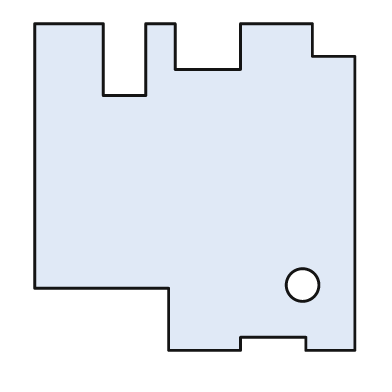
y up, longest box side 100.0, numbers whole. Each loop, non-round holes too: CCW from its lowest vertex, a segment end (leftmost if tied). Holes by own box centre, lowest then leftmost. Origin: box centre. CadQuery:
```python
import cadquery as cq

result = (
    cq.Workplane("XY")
    .moveTo(-8.0, -50.0)
    .lineTo(14.0, -50.0)
    .lineTo(14.0, -46.0)
    .lineTo(34.0, -46.0)
    .lineTo(34.0, -50.0)
    .lineTo(49.0, -50.0)
    .lineTo(49.0, 40.0)
    .lineTo(36.0, 40.0)
    .lineTo(36.0, 50.0)
    .lineTo(14.0, 50.0)
    .lineTo(14.0, 36.0)
    .lineTo(-6.0, 36.0)
    .lineTo(-6.0, 50.0)
    .lineTo(-15.0, 50.0)
    .lineTo(-15.0, 28.0)
    .lineTo(-28.0, 28.0)
    .lineTo(-28.0, 50.0)
    .lineTo(-49.0, 50.0)
    .lineTo(-49.0, -31.0)
    .lineTo(-8.0, -31.0)
    .close()
    .moveTo(33.0, -30.0)
    .circle(5.0)
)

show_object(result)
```